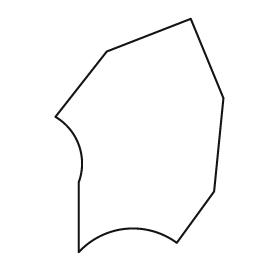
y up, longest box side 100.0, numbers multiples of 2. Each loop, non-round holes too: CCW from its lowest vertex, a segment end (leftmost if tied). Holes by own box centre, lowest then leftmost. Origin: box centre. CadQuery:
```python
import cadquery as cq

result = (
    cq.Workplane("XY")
    .moveTo(-26.0, -50.0)
    .threePointArc((-6.0, -40.0), (16.0, -46.0))
    .lineTo(32.0, -24.0)
    .lineTo(36.0, 16.0)
    .lineTo(22.0, 50.0)
    .lineTo(-14.0, 36.0)
    .lineTo(-36.0, 8.0)
    .threePointArc((-26.0, -4.0), (-26.0, -20.0))
    .close()
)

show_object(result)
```